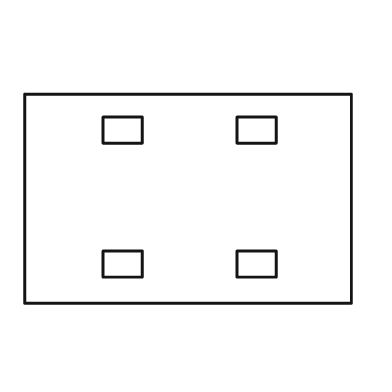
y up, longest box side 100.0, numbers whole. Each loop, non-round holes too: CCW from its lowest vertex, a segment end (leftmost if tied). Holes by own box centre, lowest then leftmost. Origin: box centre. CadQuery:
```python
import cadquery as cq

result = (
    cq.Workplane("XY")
    .moveTo(-50.0, -32.0)
    .lineTo(50.0, -32.0)
    .lineTo(50.0, 32.0)
    .lineTo(-50.0, 32.0)
    .close()
    .moveTo(-26.0, -24.0)
    .lineTo(-14.0, -24.0)
    .lineTo(-14.0, -16.0)
    .lineTo(-26.0, -16.0)
    .close()
    .moveTo(15.0, -24.0)
    .lineTo(27.0, -24.0)
    .lineTo(27.0, -16.0)
    .lineTo(15.0, -16.0)
    .close()
    .moveTo(-26.0, 17.0)
    .lineTo(-14.0, 17.0)
    .lineTo(-14.0, 25.0)
    .lineTo(-26.0, 25.0)
    .close()
    .moveTo(15.0, 17.0)
    .lineTo(27.0, 17.0)
    .lineTo(27.0, 25.0)
    .lineTo(15.0, 25.0)
    .close()
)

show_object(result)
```